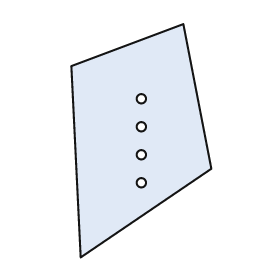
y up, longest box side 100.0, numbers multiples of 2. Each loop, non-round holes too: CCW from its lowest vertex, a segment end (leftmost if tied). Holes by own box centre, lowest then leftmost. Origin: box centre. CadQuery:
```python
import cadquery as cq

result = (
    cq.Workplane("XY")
    .moveTo(-26.0, -50.0)
    .lineTo(30.0, -12.0)
    .lineTo(18.0, 50.0)
    .lineTo(-30.0, 32.0)
    .close()
    .moveTo(0.0, -18.0)
    .circle(2.0)
    .moveTo(0.0, -6.0)
    .circle(2.0)
    .moveTo(0.0, 6.0)
    .circle(2.0)
    .moveTo(0.0, 18.0)
    .circle(2.0)
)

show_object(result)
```